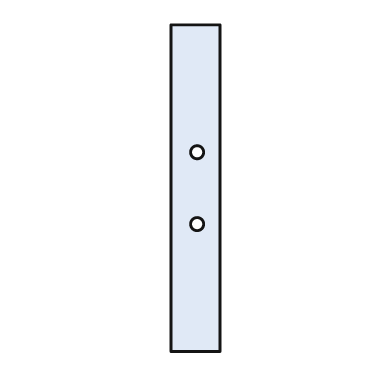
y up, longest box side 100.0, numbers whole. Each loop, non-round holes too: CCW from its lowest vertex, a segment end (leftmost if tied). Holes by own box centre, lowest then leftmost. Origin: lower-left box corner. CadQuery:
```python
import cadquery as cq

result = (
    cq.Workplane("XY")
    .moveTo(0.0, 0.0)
    .lineTo(15.0, 0.0)
    .lineTo(15.0, 100.0)
    .lineTo(0.0, 100.0)
    .close()
    .moveTo(8.0, 39.0)
    .circle(2.0)
    .moveTo(8.0, 61.0)
    .circle(2.0)
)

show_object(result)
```